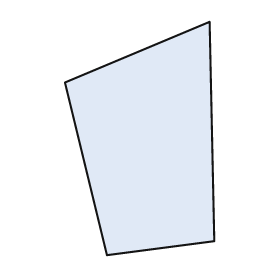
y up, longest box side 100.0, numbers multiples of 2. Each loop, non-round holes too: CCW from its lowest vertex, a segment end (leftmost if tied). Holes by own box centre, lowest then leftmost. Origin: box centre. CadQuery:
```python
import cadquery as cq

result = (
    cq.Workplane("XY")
    .moveTo(-14.0, -50.0)
    .lineTo(32.0, -44.0)
    .lineTo(30.0, 50.0)
    .lineTo(-32.0, 24.0)
    .close()
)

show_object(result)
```